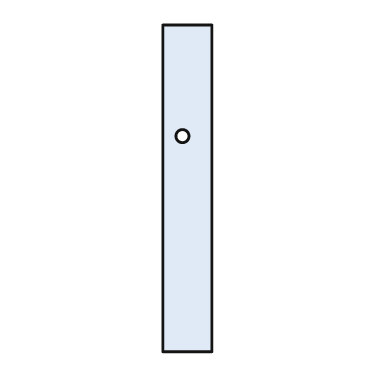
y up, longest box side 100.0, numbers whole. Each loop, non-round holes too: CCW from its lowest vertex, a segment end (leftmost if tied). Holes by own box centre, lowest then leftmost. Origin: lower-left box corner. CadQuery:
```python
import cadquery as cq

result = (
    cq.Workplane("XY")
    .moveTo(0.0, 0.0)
    .lineTo(15.0, 0.0)
    .lineTo(15.0, 100.0)
    .lineTo(0.0, 100.0)
    .close()
    .moveTo(6.0, 66.0)
    .circle(2.0)
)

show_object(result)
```